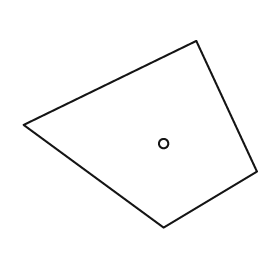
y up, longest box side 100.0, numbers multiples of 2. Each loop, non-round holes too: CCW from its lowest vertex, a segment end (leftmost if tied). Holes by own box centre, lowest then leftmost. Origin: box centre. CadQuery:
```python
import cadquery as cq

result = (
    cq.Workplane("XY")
    .moveTo(10.0, -40.0)
    .lineTo(50.0, -16.0)
    .lineTo(24.0, 40.0)
    .lineTo(-50.0, 4.0)
    .close()
    .moveTo(10.0, -4.0)
    .circle(2.0)
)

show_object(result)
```